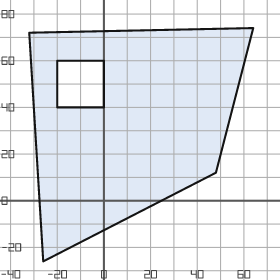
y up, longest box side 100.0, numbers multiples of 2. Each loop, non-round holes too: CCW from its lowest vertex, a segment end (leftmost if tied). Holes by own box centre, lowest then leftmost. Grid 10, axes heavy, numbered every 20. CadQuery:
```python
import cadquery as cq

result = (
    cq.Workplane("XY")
    .moveTo(-26.0, -26.0)
    .lineTo(48.0, 12.0)
    .lineTo(64.0, 74.0)
    .lineTo(-32.0, 72.0)
    .close()
    .moveTo(-20.0, 40.0)
    .lineTo(0.0, 40.0)
    .lineTo(0.0, 60.0)
    .lineTo(-20.0, 60.0)
    .close()
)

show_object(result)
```